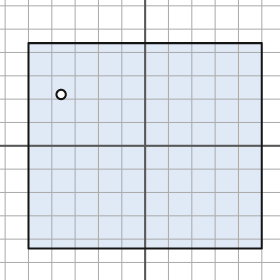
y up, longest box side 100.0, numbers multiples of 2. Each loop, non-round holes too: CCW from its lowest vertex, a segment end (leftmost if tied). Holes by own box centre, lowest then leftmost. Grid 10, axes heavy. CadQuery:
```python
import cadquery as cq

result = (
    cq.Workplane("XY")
    .moveTo(-50.0, -44.0)
    .lineTo(50.0, -44.0)
    .lineTo(50.0, 44.0)
    .lineTo(-50.0, 44.0)
    .close()
    .moveTo(-36.0, 22.0)
    .circle(2.0)
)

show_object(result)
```